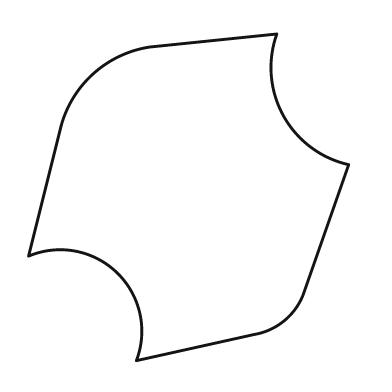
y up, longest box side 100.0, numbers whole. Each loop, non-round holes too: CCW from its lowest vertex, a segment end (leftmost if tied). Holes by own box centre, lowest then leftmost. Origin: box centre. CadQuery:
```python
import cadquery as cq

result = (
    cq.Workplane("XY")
    .moveTo(-16.0, -50.0)
    .lineTo(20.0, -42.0)
    .threePointArc((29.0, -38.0), (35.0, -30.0))
    .lineTo(49.0, 10.0)
    .threePointArc((29.0, 25.0), (27.0, 50.0))
    .lineTo(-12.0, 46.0)
    .threePointArc((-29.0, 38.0), (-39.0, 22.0))
    .lineTo(-49.0, -18.0)
    .threePointArc((-22.0, -23.0), (-16.0, -50.0))
    .close()
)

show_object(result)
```